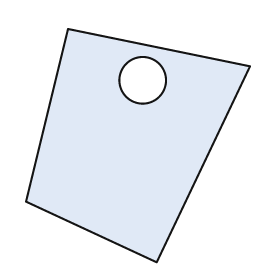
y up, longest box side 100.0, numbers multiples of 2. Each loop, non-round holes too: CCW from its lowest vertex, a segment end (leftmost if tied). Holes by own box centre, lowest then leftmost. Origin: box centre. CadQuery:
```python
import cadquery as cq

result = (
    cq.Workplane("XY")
    .moveTo(8.0, -50.0)
    .lineTo(48.0, 34.0)
    .lineTo(-30.0, 50.0)
    .lineTo(-48.0, -24.0)
    .close()
    .moveTo(2.0, 28.0)
    .circle(10.0)
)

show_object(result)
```